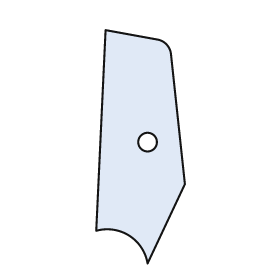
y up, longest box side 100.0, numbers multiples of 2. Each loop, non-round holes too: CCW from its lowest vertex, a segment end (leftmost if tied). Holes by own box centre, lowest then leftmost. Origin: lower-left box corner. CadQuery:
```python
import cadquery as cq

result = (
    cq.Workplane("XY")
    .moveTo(22.0, 0.0)
    .lineTo(38.0, 34.0)
    .lineTo(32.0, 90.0)
    .threePointArc((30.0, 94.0), (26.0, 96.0))
    .lineTo(4.0, 100.0)
    .lineTo(0.0, 14.0)
    .threePointArc((14.0, 12.0), (22.0, 0.0))
    .close()
    .moveTo(22.0, 52.0)
    .circle(4.0)
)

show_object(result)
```